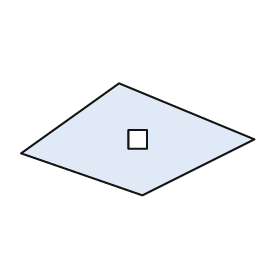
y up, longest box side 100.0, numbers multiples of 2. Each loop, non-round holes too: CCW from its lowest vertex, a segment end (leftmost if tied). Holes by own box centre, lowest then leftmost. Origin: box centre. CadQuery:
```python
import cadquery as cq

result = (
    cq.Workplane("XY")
    .moveTo(2.0, -24.0)
    .lineTo(50.0, 0.0)
    .lineTo(-8.0, 24.0)
    .lineTo(-50.0, -6.0)
    .close()
    .moveTo(-4.0, -4.0)
    .lineTo(4.0, -4.0)
    .lineTo(4.0, 4.0)
    .lineTo(-4.0, 4.0)
    .close()
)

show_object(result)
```